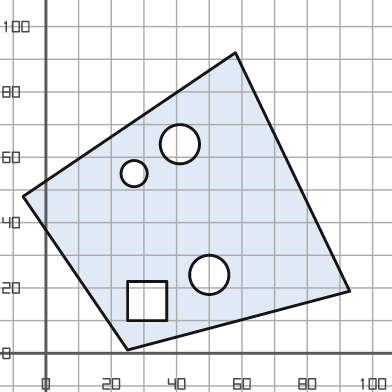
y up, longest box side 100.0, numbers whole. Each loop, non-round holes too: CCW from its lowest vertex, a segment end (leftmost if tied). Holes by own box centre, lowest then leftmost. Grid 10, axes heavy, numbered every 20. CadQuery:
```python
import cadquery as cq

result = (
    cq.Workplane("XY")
    .moveTo(25.0, 1.0)
    .lineTo(93.0, 19.0)
    .lineTo(58.0, 92.0)
    .lineTo(-7.0, 48.0)
    .close()
    .moveTo(25.0, 10.0)
    .lineTo(37.0, 10.0)
    .lineTo(37.0, 22.0)
    .lineTo(25.0, 22.0)
    .close()
    .moveTo(50.0, 24.0)
    .circle(6.0)
    .moveTo(27.0, 55.0)
    .circle(4.0)
    .moveTo(41.0, 64.0)
    .circle(6.0)
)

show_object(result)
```